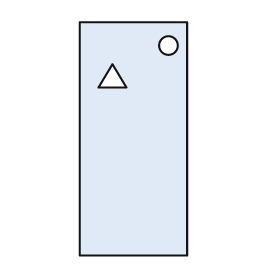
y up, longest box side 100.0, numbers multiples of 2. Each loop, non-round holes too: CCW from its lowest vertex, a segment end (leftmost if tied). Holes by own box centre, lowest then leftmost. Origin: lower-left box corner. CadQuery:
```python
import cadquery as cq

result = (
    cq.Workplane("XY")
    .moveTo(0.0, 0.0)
    .lineTo(46.0, 0.0)
    .lineTo(46.0, 100.0)
    .lineTo(0.0, 100.0)
    .close()
    .moveTo(8.0, 72.0)
    .lineTo(20.0, 72.0)
    .lineTo(14.0, 82.0)
    .close()
    .moveTo(38.0, 90.0)
    .circle(4.0)
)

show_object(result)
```